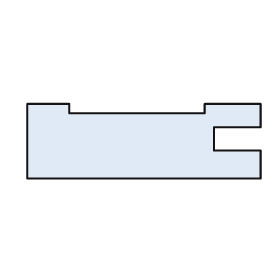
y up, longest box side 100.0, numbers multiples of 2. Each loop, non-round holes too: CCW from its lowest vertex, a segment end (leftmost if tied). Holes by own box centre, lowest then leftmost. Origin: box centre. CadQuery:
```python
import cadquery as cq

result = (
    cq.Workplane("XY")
    .moveTo(-50.0, -16.0)
    .lineTo(50.0, -16.0)
    .lineTo(50.0, -4.0)
    .lineTo(30.0, -4.0)
    .lineTo(30.0, 6.0)
    .lineTo(50.0, 6.0)
    .lineTo(50.0, 16.0)
    .lineTo(26.0, 16.0)
    .lineTo(26.0, 12.0)
    .lineTo(-32.0, 12.0)
    .lineTo(-32.0, 16.0)
    .lineTo(-50.0, 16.0)
    .close()
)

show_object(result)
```